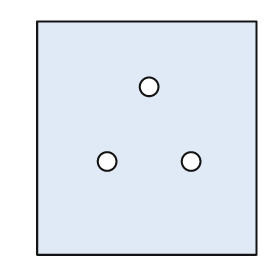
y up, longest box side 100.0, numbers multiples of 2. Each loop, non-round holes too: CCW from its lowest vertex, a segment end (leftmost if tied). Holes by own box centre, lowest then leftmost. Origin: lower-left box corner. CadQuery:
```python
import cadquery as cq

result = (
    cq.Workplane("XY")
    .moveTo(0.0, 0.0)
    .lineTo(94.0, 0.0)
    .lineTo(94.0, 100.0)
    .lineTo(0.0, 100.0)
    .close()
    .moveTo(30.0, 40.0)
    .circle(4.0)
    .moveTo(66.0, 40.0)
    .circle(4.0)
    .moveTo(48.0, 72.0)
    .circle(4.0)
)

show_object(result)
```